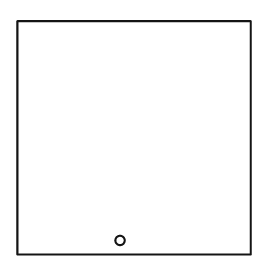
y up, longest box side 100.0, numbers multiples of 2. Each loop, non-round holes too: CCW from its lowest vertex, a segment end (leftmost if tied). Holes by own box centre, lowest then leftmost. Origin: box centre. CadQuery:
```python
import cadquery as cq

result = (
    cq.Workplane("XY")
    .moveTo(-50.0, -50.0)
    .lineTo(50.0, -50.0)
    .lineTo(50.0, 50.0)
    .lineTo(-50.0, 50.0)
    .close()
    .moveTo(-6.0, -44.0)
    .circle(2.0)
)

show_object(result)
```